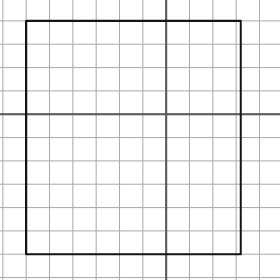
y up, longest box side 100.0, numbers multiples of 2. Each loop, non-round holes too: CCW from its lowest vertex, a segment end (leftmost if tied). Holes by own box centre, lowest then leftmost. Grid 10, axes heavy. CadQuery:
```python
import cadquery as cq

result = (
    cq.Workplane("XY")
    .moveTo(-60.0, -60.0)
    .lineTo(32.0, -60.0)
    .lineTo(32.0, 40.0)
    .lineTo(-60.0, 40.0)
    .close()
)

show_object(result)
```